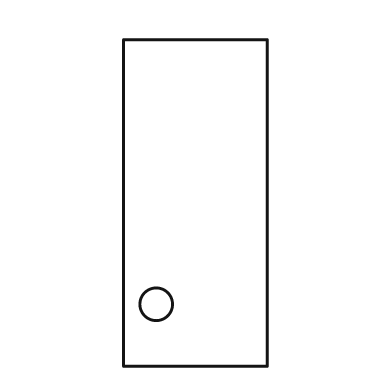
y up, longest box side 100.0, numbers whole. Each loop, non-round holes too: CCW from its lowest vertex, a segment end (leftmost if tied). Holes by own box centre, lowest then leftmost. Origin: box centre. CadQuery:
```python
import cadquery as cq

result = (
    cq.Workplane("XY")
    .moveTo(-22.0, -50.0)
    .lineTo(22.0, -50.0)
    .lineTo(22.0, 50.0)
    .lineTo(-22.0, 50.0)
    .close()
    .moveTo(-12.0, -31.0)
    .circle(5.0)
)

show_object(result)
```